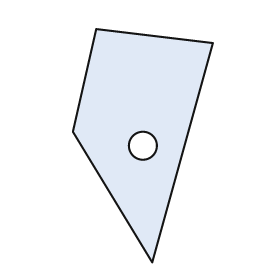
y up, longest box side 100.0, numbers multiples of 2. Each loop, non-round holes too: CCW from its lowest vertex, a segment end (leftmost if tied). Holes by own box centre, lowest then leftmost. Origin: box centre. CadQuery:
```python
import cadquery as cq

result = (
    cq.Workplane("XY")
    .moveTo(4.0, -50.0)
    .lineTo(30.0, 44.0)
    .lineTo(-20.0, 50.0)
    .lineTo(-30.0, 6.0)
    .close()
    .moveTo(0.0, 0.0)
    .circle(6.0)
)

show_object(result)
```